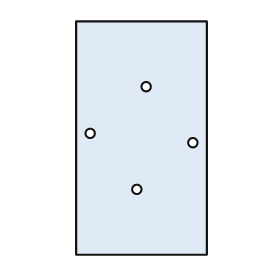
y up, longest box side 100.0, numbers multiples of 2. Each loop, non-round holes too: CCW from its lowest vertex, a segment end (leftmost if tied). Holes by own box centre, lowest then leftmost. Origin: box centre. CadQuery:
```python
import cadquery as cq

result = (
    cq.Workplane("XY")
    .moveTo(-28.0, -50.0)
    .lineTo(28.0, -50.0)
    .lineTo(28.0, 50.0)
    .lineTo(-28.0, 50.0)
    .close()
    .moveTo(-2.0, -22.0)
    .circle(2.0)
    .moveTo(22.0, -2.0)
    .circle(2.0)
    .moveTo(-22.0, 2.0)
    .circle(2.0)
    .moveTo(2.0, 22.0)
    .circle(2.0)
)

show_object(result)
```